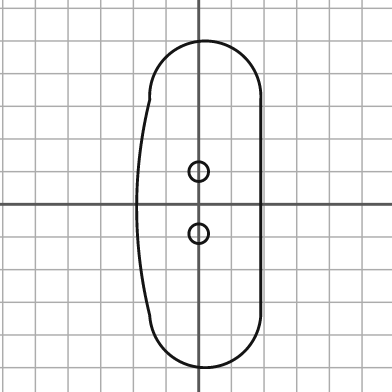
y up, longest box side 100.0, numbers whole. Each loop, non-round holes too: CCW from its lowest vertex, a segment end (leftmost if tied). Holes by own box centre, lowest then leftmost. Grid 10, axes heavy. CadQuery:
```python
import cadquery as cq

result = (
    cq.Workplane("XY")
    .moveTo(-15.0, -34.0)
    .threePointArc((2.0, -50.0), (19.0, -34.0))
    .lineTo(19.0, 32.0)
    .threePointArc((2.0, 50.0), (-15.0, 32.0))
    .threePointArc((-19.0, -1.0), (-15.0, -34.0))
    .close()
    .moveTo(0.0, -9.0)
    .circle(3.0)
    .moveTo(0.0, 10.0)
    .circle(3.0)
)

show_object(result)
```